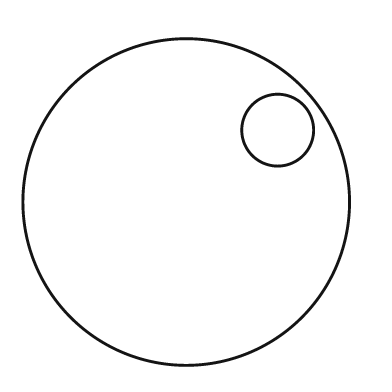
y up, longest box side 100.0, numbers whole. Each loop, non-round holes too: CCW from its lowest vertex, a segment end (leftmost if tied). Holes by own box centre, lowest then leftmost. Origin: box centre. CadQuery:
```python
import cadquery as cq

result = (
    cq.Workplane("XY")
    .moveTo(0.0, 0.0)
    .circle(50.0)
    .moveTo(28.0, 22.0)
    .circle(11.0)
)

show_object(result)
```